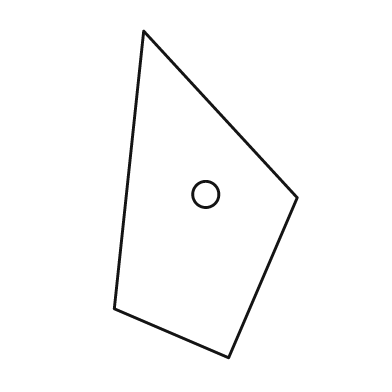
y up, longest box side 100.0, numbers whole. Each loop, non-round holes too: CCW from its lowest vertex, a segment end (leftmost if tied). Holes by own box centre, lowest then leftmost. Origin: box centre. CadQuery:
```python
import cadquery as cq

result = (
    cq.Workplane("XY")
    .moveTo(7.0, -50.0)
    .lineTo(28.0, -1.0)
    .lineTo(-19.0, 50.0)
    .lineTo(-28.0, -35.0)
    .close()
    .moveTo(0.0, 0.0)
    .circle(4.0)
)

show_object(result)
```